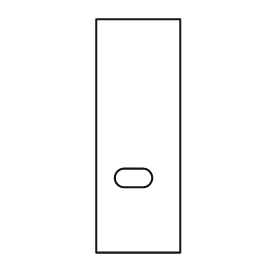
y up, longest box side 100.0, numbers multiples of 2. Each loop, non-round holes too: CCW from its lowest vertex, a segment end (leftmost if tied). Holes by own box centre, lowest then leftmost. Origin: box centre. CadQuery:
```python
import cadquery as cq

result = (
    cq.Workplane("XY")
    .moveTo(-18.0, -50.0)
    .lineTo(18.0, -50.0)
    .lineTo(18.0, 50.0)
    .lineTo(-18.0, 50.0)
    .close()
    .moveTo(-6.0, -22.0)
    .lineTo(2.0, -22.0)
    .threePointArc((6.0, -18.0), (2.0, -14.0))
    .lineTo(-6.0, -14.0)
    .threePointArc((-10.0, -18.0), (-6.0, -22.0))
    .close()
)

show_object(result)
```